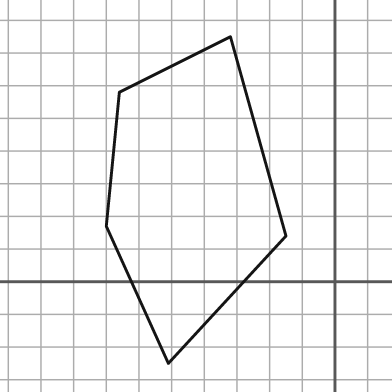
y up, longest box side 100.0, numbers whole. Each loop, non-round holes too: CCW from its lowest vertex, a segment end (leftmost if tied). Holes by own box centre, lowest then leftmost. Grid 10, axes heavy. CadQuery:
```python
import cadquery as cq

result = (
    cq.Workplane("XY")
    .moveTo(-51.0, -25.0)
    .lineTo(-15.0, 14.0)
    .lineTo(-32.0, 75.0)
    .lineTo(-66.0, 58.0)
    .lineTo(-70.0, 17.0)
    .close()
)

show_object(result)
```